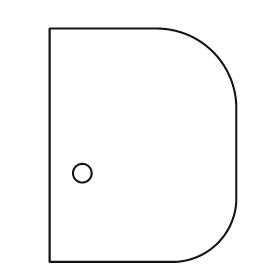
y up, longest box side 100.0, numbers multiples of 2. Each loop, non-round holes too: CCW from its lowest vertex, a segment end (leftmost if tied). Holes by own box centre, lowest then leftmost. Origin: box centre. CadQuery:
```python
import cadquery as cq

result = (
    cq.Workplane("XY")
    .moveTo(-40.0, -50.0)
    .lineTo(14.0, -50.0)
    .threePointArc((32.0, -42.0), (40.0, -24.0))
    .lineTo(40.0, 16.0)
    .threePointArc((30.0, 40.0), (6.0, 50.0))
    .lineTo(-40.0, 50.0)
    .close()
    .moveTo(-26.0, -12.0)
    .circle(4.0)
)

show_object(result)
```